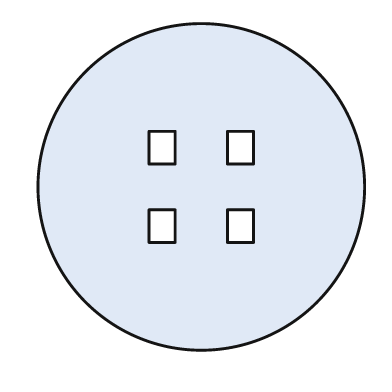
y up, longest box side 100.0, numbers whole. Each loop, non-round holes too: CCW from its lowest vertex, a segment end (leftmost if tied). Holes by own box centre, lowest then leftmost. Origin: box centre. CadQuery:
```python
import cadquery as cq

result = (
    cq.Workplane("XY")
    .moveTo(0.0, 0.0)
    .circle(50.0)
    .moveTo(-16.0, -17.0)
    .lineTo(-8.0, -17.0)
    .lineTo(-8.0, -7.0)
    .lineTo(-16.0, -7.0)
    .close()
    .moveTo(8.0, -17.0)
    .lineTo(16.0, -17.0)
    .lineTo(16.0, -7.0)
    .lineTo(8.0, -7.0)
    .close()
    .moveTo(-16.0, 7.0)
    .lineTo(-8.0, 7.0)
    .lineTo(-8.0, 17.0)
    .lineTo(-16.0, 17.0)
    .close()
    .moveTo(8.0, 7.0)
    .lineTo(16.0, 7.0)
    .lineTo(16.0, 17.0)
    .lineTo(8.0, 17.0)
    .close()
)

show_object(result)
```